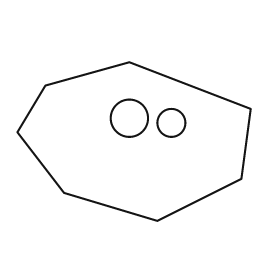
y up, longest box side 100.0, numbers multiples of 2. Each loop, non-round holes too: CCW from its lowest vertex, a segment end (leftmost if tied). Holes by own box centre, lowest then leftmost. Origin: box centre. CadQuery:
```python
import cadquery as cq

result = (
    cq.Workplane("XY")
    .moveTo(10.0, -34.0)
    .lineTo(46.0, -16.0)
    .lineTo(50.0, 14.0)
    .lineTo(-2.0, 34.0)
    .lineTo(-38.0, 24.0)
    .lineTo(-50.0, 4.0)
    .lineTo(-30.0, -22.0)
    .close()
    .moveTo(16.0, 8.0)
    .circle(6.0)
    .moveTo(-2.0, 10.0)
    .circle(8.0)
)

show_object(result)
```